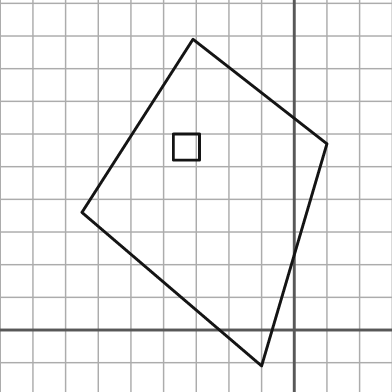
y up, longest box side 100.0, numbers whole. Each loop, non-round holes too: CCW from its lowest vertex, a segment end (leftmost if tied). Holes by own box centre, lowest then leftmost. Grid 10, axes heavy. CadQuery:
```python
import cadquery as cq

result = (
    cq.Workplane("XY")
    .moveTo(-10.0, -11.0)
    .lineTo(10.0, 57.0)
    .lineTo(-31.0, 89.0)
    .lineTo(-65.0, 36.0)
    .close()
    .moveTo(-37.0, 52.0)
    .lineTo(-29.0, 52.0)
    .lineTo(-29.0, 60.0)
    .lineTo(-37.0, 60.0)
    .close()
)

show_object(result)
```